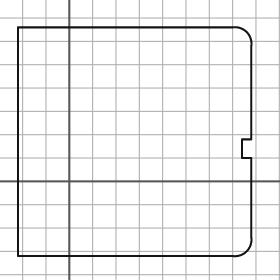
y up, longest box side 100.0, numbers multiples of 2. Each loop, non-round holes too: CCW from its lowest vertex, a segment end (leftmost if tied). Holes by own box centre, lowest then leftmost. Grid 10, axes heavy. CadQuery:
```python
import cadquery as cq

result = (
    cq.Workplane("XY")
    .moveTo(-22.0, -32.0)
    .lineTo(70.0, -32.0)
    .threePointArc((76.0, -30.0), (78.0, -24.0))
    .lineTo(78.0, 10.0)
    .lineTo(74.0, 10.0)
    .lineTo(74.0, 18.0)
    .lineTo(78.0, 18.0)
    .lineTo(78.0, 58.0)
    .threePointArc((76.0, 64.0), (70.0, 66.0))
    .lineTo(-22.0, 66.0)
    .close()
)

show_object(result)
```